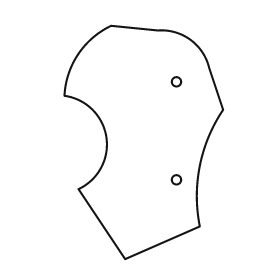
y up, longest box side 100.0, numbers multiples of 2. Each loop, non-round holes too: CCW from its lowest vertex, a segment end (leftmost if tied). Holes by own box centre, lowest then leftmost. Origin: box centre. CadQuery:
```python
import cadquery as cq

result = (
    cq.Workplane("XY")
    .moveTo(-8.0, -50.0)
    .lineTo(24.0, -36.0)
    .threePointArc((24.0, -10.0), (34.0, 14.0))
    .lineTo(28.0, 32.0)
    .threePointArc((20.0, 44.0), (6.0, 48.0))
    .lineTo(-14.0, 50.0)
    .threePointArc((-28.0, 38.0), (-34.0, 20.0))
    .threePointArc((-16.0, 2.0), (-28.0, -20.0))
    .close()
    .moveTo(14.0, -16.0)
    .circle(2.0)
    .moveTo(14.0, 26.0)
    .circle(2.0)
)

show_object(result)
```